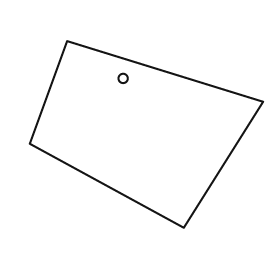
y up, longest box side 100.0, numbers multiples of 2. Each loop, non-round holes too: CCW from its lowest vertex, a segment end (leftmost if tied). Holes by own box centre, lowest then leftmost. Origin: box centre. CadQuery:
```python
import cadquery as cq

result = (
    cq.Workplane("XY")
    .moveTo(16.0, -40.0)
    .lineTo(50.0, 14.0)
    .lineTo(-34.0, 40.0)
    .lineTo(-50.0, -4.0)
    .close()
    .moveTo(-10.0, 24.0)
    .circle(2.0)
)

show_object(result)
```